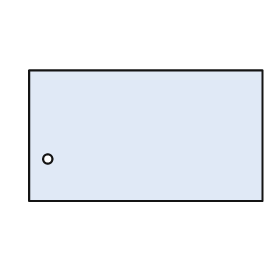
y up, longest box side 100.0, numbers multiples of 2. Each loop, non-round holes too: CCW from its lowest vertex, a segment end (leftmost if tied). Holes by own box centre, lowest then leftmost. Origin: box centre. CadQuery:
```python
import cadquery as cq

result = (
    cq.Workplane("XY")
    .moveTo(-50.0, -28.0)
    .lineTo(50.0, -28.0)
    .lineTo(50.0, 28.0)
    .lineTo(-50.0, 28.0)
    .close()
    .moveTo(-42.0, -10.0)
    .circle(2.0)
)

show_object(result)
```